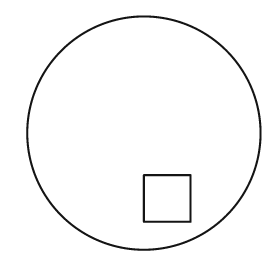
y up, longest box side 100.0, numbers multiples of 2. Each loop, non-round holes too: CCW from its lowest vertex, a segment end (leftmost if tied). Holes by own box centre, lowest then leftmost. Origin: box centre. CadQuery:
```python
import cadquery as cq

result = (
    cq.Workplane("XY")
    .moveTo(0.0, 0.0)
    .circle(50.0)
    .moveTo(0.0, -38.0)
    .lineTo(20.0, -38.0)
    .lineTo(20.0, -18.0)
    .lineTo(0.0, -18.0)
    .close()
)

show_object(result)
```